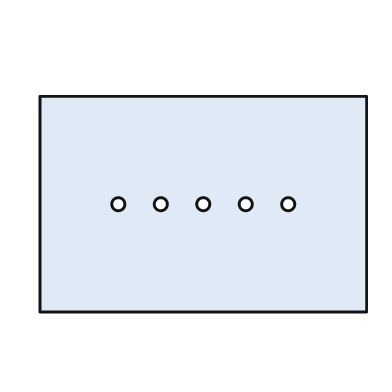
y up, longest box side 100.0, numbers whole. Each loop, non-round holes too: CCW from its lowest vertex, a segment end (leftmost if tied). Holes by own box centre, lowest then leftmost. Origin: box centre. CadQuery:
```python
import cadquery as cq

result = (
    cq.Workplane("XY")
    .moveTo(-50.0, -33.0)
    .lineTo(50.0, -33.0)
    .lineTo(50.0, 33.0)
    .lineTo(-50.0, 33.0)
    .close()
    .moveTo(-26.0, 0.0)
    .circle(2.0)
    .moveTo(-13.0, 0.0)
    .circle(2.0)
    .moveTo(0.0, 0.0)
    .circle(2.0)
    .moveTo(13.0, 0.0)
    .circle(2.0)
    .moveTo(26.0, 0.0)
    .circle(2.0)
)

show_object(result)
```